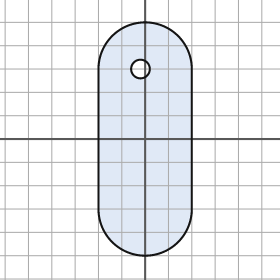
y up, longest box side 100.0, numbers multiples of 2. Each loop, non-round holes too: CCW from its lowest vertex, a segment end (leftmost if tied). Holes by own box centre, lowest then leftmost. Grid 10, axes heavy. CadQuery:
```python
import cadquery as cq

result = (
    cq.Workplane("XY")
    .moveTo(-20.0, -30.0)
    .threePointArc((0.0, -50.0), (20.0, -30.0))
    .lineTo(20.0, 30.0)
    .threePointArc((0.0, 50.0), (-20.0, 30.0))
    .close()
    .moveTo(-2.0, 30.0)
    .circle(4.0)
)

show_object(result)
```